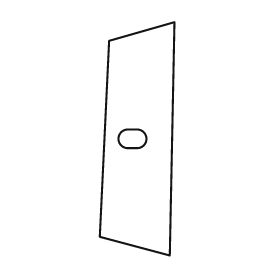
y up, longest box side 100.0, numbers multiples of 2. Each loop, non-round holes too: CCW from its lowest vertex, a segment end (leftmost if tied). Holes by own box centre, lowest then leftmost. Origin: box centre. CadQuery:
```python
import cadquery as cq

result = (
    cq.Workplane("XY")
    .moveTo(14.0, -50.0)
    .lineTo(16.0, 50.0)
    .lineTo(-12.0, 42.0)
    .lineTo(-16.0, -42.0)
    .close()
    .moveTo(-4.0, -4.0)
    .lineTo(0.0, -4.0)
    .threePointArc((4.0, 0.0), (0.0, 4.0))
    .lineTo(-4.0, 4.0)
    .threePointArc((-8.0, 0.0), (-4.0, -4.0))
    .close()
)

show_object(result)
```